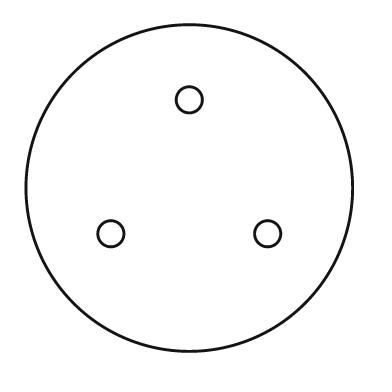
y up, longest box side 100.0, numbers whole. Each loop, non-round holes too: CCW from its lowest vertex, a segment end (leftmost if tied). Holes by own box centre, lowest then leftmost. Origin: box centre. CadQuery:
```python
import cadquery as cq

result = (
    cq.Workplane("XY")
    .moveTo(0.0, 0.0)
    .circle(50.0)
    .moveTo(-24.0, -14.0)
    .circle(4.0)
    .moveTo(24.0, -14.0)
    .circle(4.0)
    .moveTo(0.0, 27.0)
    .circle(4.0)
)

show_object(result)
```